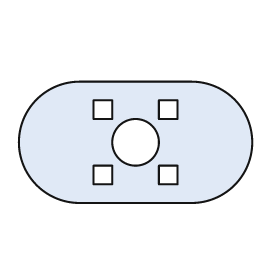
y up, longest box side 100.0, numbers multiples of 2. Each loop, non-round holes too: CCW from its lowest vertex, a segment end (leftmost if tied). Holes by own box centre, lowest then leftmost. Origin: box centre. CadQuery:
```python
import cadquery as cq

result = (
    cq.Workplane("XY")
    .moveTo(-24.0, -26.0)
    .lineTo(24.0, -26.0)
    .threePointArc((50.0, 0.0), (24.0, 26.0))
    .lineTo(-24.0, 26.0)
    .threePointArc((-50.0, 0.0), (-24.0, -26.0))
    .close()
    .moveTo(-18.0, -18.0)
    .lineTo(-10.0, -18.0)
    .lineTo(-10.0, -10.0)
    .lineTo(-18.0, -10.0)
    .close()
    .moveTo(10.0, -18.0)
    .lineTo(18.0, -18.0)
    .lineTo(18.0, -10.0)
    .lineTo(10.0, -10.0)
    .close()
    .moveTo(0.0, 0.0)
    .circle(10.0)
    .moveTo(-18.0, 10.0)
    .lineTo(-10.0, 10.0)
    .lineTo(-10.0, 18.0)
    .lineTo(-18.0, 18.0)
    .close()
    .moveTo(10.0, 10.0)
    .lineTo(18.0, 10.0)
    .lineTo(18.0, 18.0)
    .lineTo(10.0, 18.0)
    .close()
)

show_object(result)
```